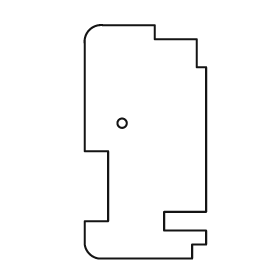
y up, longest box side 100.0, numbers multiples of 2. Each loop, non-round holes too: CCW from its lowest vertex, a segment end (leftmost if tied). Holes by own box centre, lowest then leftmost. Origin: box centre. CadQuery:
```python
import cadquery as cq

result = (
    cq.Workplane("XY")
    .moveTo(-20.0, -50.0)
    .lineTo(20.0, -50.0)
    .lineTo(20.0, -44.0)
    .lineTo(26.0, -44.0)
    .lineTo(26.0, -38.0)
    .lineTo(8.0, -38.0)
    .lineTo(8.0, -30.0)
    .lineTo(26.0, -30.0)
    .lineTo(26.0, 32.0)
    .lineTo(22.0, 32.0)
    .lineTo(22.0, 44.0)
    .lineTo(4.0, 44.0)
    .lineTo(4.0, 50.0)
    .lineTo(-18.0, 50.0)
    .threePointArc((-24.0, 48.0), (-26.0, 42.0))
    .lineTo(-26.0, -4.0)
    .lineTo(-16.0, -4.0)
    .lineTo(-16.0, -34.0)
    .lineTo(-26.0, -34.0)
    .lineTo(-26.0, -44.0)
    .threePointArc((-24.0, -48.0), (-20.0, -50.0))
    .close()
    .moveTo(-10.0, 8.0)
    .circle(2.0)
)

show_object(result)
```